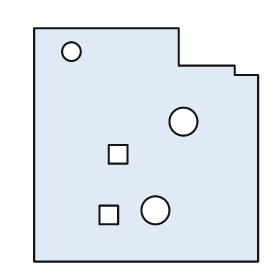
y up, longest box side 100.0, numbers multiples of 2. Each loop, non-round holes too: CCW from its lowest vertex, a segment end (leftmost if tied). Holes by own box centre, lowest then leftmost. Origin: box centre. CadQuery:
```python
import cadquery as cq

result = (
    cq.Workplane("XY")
    .moveTo(-48.0, -50.0)
    .lineTo(48.0, -50.0)
    .lineTo(48.0, 30.0)
    .lineTo(38.0, 30.0)
    .lineTo(38.0, 34.0)
    .lineTo(14.0, 34.0)
    .lineTo(14.0, 50.0)
    .lineTo(-48.0, 50.0)
    .close()
    .moveTo(-20.0, -34.0)
    .lineTo(-12.0, -34.0)
    .lineTo(-12.0, -26.0)
    .lineTo(-20.0, -26.0)
    .close()
    .moveTo(4.0, -28.0)
    .circle(6.0)
    .moveTo(-16.0, -8.0)
    .lineTo(-8.0, -8.0)
    .lineTo(-8.0, 0.0)
    .lineTo(-16.0, 0.0)
    .close()
    .moveTo(16.0, 10.0)
    .circle(6.0)
    .moveTo(-32.0, 40.0)
    .circle(4.0)
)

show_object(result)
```